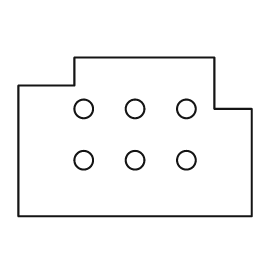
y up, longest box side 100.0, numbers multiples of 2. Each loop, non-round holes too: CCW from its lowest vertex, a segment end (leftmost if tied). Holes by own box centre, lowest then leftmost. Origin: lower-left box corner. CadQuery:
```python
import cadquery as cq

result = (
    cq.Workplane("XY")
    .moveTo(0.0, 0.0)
    .lineTo(100.0, 0.0)
    .lineTo(100.0, 46.0)
    .lineTo(84.0, 46.0)
    .lineTo(84.0, 68.0)
    .lineTo(24.0, 68.0)
    .lineTo(24.0, 56.0)
    .lineTo(0.0, 56.0)
    .close()
    .moveTo(28.0, 24.0)
    .circle(4.0)
    .moveTo(50.0, 24.0)
    .circle(4.0)
    .moveTo(72.0, 24.0)
    .circle(4.0)
    .moveTo(28.0, 46.0)
    .circle(4.0)
    .moveTo(50.0, 46.0)
    .circle(4.0)
    .moveTo(72.0, 46.0)
    .circle(4.0)
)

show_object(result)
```